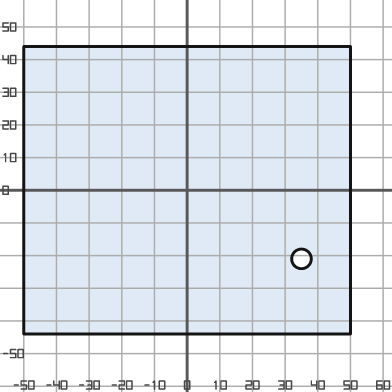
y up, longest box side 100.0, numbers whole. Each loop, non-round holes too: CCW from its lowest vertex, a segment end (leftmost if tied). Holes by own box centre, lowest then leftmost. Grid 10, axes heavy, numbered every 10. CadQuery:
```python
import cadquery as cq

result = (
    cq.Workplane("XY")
    .moveTo(-50.0, -44.0)
    .lineTo(50.0, -44.0)
    .lineTo(50.0, 44.0)
    .lineTo(-50.0, 44.0)
    .close()
    .moveTo(35.0, -21.0)
    .circle(3.0)
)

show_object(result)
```